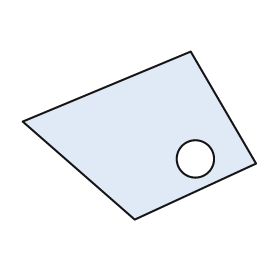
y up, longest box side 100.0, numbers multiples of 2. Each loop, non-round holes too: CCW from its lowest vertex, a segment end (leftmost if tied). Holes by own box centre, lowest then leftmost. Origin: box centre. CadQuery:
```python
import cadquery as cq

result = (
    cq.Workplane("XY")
    .moveTo(-2.0, -36.0)
    .lineTo(50.0, -12.0)
    .lineTo(22.0, 36.0)
    .lineTo(-50.0, 6.0)
    .close()
    .moveTo(24.0, -10.0)
    .circle(8.0)
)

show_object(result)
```